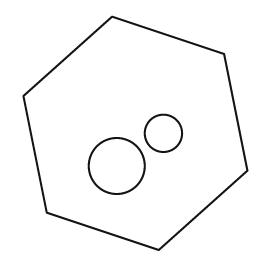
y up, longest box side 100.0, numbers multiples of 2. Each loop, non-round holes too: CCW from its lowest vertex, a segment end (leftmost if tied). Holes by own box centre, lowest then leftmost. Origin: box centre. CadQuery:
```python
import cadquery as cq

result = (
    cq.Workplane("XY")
    .moveTo(10.0, -50.0)
    .lineTo(48.0, -16.0)
    .lineTo(38.0, 34.0)
    .lineTo(-10.0, 50.0)
    .lineTo(-48.0, 16.0)
    .lineTo(-38.0, -34.0)
    .close()
    .moveTo(-8.0, -14.0)
    .circle(12.0)
    .moveTo(12.0, 0.0)
    .circle(8.0)
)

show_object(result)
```